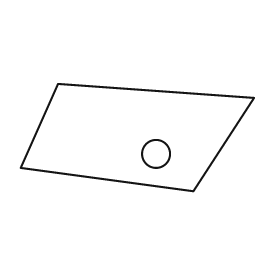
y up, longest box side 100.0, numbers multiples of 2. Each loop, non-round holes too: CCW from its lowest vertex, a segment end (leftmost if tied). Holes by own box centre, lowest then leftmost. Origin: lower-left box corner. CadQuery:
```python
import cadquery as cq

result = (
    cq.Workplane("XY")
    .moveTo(74.0, 0.0)
    .lineTo(100.0, 40.0)
    .lineTo(16.0, 46.0)
    .lineTo(0.0, 10.0)
    .close()
    .moveTo(58.0, 16.0)
    .circle(6.0)
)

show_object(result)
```